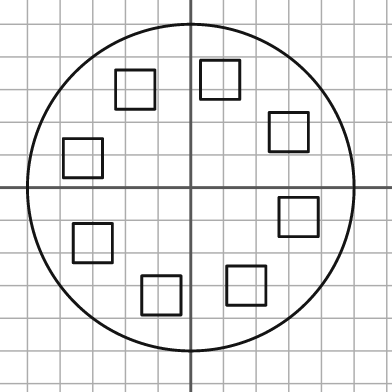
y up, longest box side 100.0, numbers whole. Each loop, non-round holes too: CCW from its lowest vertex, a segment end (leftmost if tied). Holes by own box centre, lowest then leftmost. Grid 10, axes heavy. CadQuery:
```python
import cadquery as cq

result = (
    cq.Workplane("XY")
    .moveTo(0.0, 0.0)
    .circle(50.0)
    .moveTo(-15.0, -39.0)
    .lineTo(-3.0, -39.0)
    .lineTo(-3.0, -27.0)
    .lineTo(-15.0, -27.0)
    .close()
    .moveTo(11.0, -36.0)
    .lineTo(23.0, -36.0)
    .lineTo(23.0, -24.0)
    .lineTo(11.0, -24.0)
    .close()
    .moveTo(-36.0, -23.0)
    .lineTo(-24.0, -23.0)
    .lineTo(-24.0, -11.0)
    .lineTo(-36.0, -11.0)
    .close()
    .moveTo(27.0, -15.0)
    .lineTo(39.0, -15.0)
    .lineTo(39.0, -3.0)
    .lineTo(27.0, -3.0)
    .close()
    .moveTo(-39.0, 3.0)
    .lineTo(-27.0, 3.0)
    .lineTo(-27.0, 15.0)
    .lineTo(-39.0, 15.0)
    .close()
    .moveTo(24.0, 11.0)
    .lineTo(36.0, 11.0)
    .lineTo(36.0, 23.0)
    .lineTo(24.0, 23.0)
    .close()
    .moveTo(-23.0, 24.0)
    .lineTo(-11.0, 24.0)
    .lineTo(-11.0, 36.0)
    .lineTo(-23.0, 36.0)
    .close()
    .moveTo(3.0, 27.0)
    .lineTo(15.0, 27.0)
    .lineTo(15.0, 39.0)
    .lineTo(3.0, 39.0)
    .close()
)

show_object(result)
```